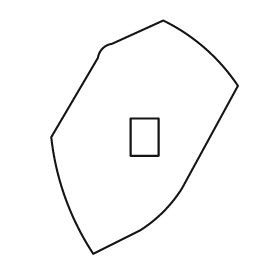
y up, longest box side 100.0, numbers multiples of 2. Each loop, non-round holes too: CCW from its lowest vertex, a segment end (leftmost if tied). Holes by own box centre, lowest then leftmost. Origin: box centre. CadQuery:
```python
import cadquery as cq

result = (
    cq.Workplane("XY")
    .moveTo(-22.0, -50.0)
    .lineTo(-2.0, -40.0)
    .threePointArc((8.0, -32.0), (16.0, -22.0))
    .lineTo(40.0, 22.0)
    .threePointArc((26.0, 38.0), (8.0, 50.0))
    .lineTo(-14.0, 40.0)
    .threePointArc((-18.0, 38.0), (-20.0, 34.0))
    .lineTo(-40.0, 0.0)
    .threePointArc((-34.0, -26.0), (-22.0, -50.0))
    .close()
    .moveTo(-6.0, -8.0)
    .lineTo(6.0, -8.0)
    .lineTo(6.0, 8.0)
    .lineTo(-6.0, 8.0)
    .close()
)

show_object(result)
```